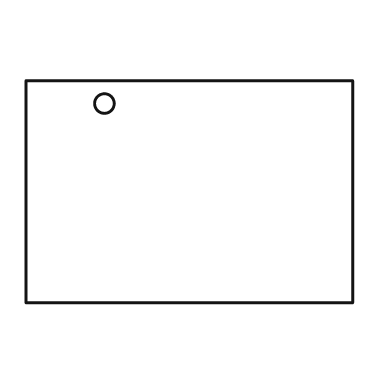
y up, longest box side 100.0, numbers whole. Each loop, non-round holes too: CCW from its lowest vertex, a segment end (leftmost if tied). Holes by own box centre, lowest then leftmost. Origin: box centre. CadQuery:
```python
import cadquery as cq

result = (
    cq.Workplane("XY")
    .moveTo(-50.0, -34.0)
    .lineTo(50.0, -34.0)
    .lineTo(50.0, 34.0)
    .lineTo(-50.0, 34.0)
    .close()
    .moveTo(-26.0, 27.0)
    .circle(3.0)
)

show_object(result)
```